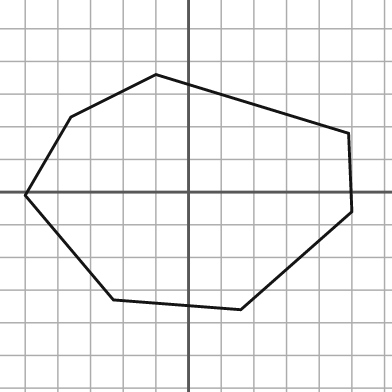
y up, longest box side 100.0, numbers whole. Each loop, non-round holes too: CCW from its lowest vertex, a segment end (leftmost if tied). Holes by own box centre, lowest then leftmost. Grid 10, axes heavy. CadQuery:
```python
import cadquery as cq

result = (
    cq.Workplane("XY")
    .moveTo(16.0, -36.0)
    .lineTo(50.0, -6.0)
    .lineTo(49.0, 18.0)
    .lineTo(-10.0, 36.0)
    .lineTo(-36.0, 23.0)
    .lineTo(-50.0, -1.0)
    .lineTo(-23.0, -33.0)
    .close()
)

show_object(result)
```